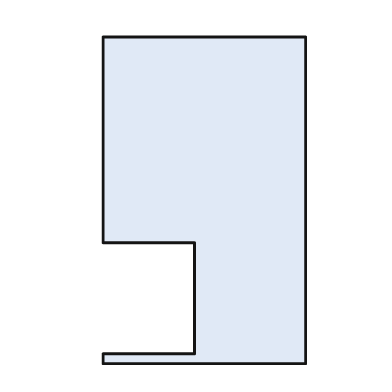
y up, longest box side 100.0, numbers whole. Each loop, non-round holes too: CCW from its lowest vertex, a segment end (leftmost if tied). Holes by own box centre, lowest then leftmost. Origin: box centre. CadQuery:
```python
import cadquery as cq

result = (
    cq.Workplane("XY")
    .moveTo(-31.0, -50.0)
    .lineTo(31.0, -50.0)
    .lineTo(31.0, 50.0)
    .lineTo(-31.0, 50.0)
    .lineTo(-31.0, -13.0)
    .lineTo(-3.0, -13.0)
    .lineTo(-3.0, -47.0)
    .lineTo(-31.0, -47.0)
    .close()
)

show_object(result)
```